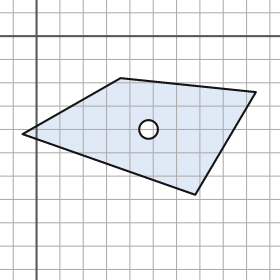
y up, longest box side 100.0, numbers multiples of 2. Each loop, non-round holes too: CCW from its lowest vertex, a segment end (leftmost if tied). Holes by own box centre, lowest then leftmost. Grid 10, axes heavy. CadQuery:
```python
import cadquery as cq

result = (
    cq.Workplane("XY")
    .moveTo(68.0, -68.0)
    .lineTo(94.0, -24.0)
    .lineTo(36.0, -18.0)
    .lineTo(-6.0, -42.0)
    .close()
    .moveTo(48.0, -40.0)
    .circle(4.0)
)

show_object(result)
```